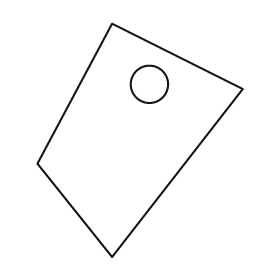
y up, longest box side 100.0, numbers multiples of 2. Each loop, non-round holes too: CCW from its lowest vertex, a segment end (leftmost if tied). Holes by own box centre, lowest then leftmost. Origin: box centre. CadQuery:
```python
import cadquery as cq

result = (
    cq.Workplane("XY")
    .moveTo(-12.0, -50.0)
    .lineTo(44.0, 22.0)
    .lineTo(-12.0, 50.0)
    .lineTo(-44.0, -10.0)
    .close()
    .moveTo(4.0, 24.0)
    .circle(8.0)
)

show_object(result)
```